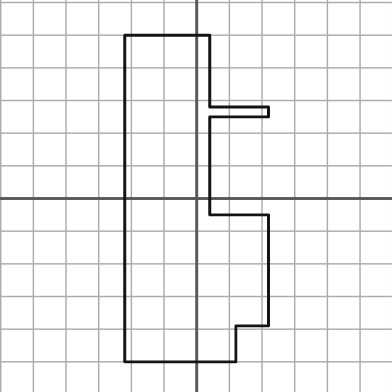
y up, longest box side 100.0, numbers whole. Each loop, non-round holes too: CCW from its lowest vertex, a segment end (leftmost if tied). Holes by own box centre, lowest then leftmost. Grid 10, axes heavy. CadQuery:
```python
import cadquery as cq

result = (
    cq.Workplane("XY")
    .moveTo(-22.0, -50.0)
    .lineTo(12.0, -50.0)
    .lineTo(12.0, -39.0)
    .lineTo(22.0, -39.0)
    .lineTo(22.0, -5.0)
    .lineTo(4.0, -5.0)
    .lineTo(4.0, 25.0)
    .lineTo(22.0, 25.0)
    .lineTo(22.0, 28.0)
    .lineTo(4.0, 28.0)
    .lineTo(4.0, 50.0)
    .lineTo(-22.0, 50.0)
    .close()
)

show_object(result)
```